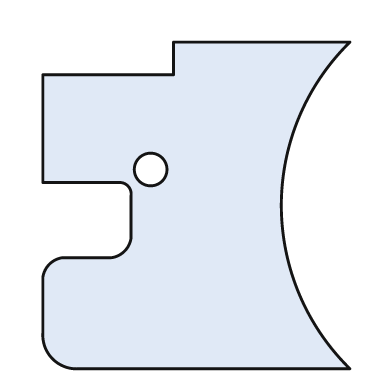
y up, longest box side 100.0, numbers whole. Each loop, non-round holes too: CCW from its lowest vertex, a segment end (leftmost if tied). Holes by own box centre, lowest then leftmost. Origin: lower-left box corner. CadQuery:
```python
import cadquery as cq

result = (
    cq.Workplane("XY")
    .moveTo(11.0, 0.0)
    .lineTo(94.0, 0.0)
    .threePointArc((73.0, 50.0), (94.0, 100.0))
    .lineTo(40.0, 100.0)
    .lineTo(40.0, 90.0)
    .lineTo(0.0, 90.0)
    .lineTo(0.0, 57.0)
    .lineTo(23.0, 57.0)
    .threePointArc((26.0, 56.0), (27.0, 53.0))
    .lineTo(27.0, 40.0)
    .threePointArc((25.0, 36.0), (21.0, 34.0))
    .lineTo(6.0, 34.0)
    .threePointArc((2.0, 32.0), (0.0, 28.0))
    .lineTo(0.0, 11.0)
    .threePointArc((3.0, 3.0), (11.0, 0.0))
    .close()
    .moveTo(33.0, 61.0)
    .circle(5.0)
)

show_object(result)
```